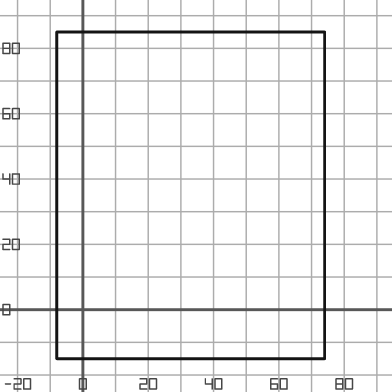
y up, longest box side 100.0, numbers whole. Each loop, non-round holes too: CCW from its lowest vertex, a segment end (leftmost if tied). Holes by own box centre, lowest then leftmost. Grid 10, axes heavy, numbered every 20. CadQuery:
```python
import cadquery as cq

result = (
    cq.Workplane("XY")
    .moveTo(-8.0, -15.0)
    .lineTo(74.0, -15.0)
    .lineTo(74.0, 85.0)
    .lineTo(-8.0, 85.0)
    .close()
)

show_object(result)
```